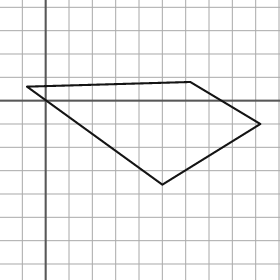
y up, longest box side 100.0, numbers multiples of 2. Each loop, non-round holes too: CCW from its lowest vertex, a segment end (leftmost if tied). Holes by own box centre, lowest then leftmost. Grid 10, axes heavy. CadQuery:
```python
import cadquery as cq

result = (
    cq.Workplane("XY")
    .moveTo(50.0, -36.0)
    .lineTo(92.0, -10.0)
    .lineTo(62.0, 8.0)
    .lineTo(-8.0, 6.0)
    .close()
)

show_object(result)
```